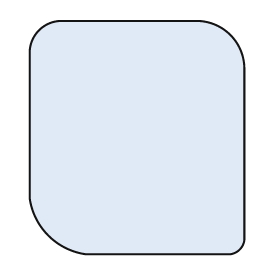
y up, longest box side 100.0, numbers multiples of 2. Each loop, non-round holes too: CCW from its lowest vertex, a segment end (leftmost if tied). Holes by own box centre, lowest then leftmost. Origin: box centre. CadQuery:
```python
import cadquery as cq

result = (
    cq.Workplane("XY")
    .moveTo(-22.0, -50.0)
    .lineTo(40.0, -50.0)
    .threePointArc((44.0, -48.0), (46.0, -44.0))
    .lineTo(46.0, 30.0)
    .threePointArc((40.0, 44.0), (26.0, 50.0))
    .lineTo(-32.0, 50.0)
    .threePointArc((-42.0, 46.0), (-46.0, 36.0))
    .lineTo(-46.0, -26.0)
    .threePointArc((-38.0, -42.0), (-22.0, -50.0))
    .close()
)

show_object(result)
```